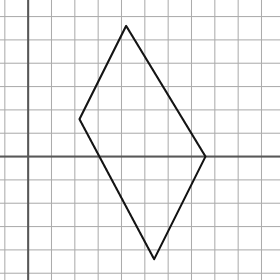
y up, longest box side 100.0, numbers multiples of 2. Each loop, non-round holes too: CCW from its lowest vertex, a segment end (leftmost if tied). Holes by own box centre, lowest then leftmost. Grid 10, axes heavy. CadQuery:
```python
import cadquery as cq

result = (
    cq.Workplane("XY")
    .moveTo(54.0, -44.0)
    .lineTo(76.0, 0.0)
    .lineTo(42.0, 56.0)
    .lineTo(22.0, 16.0)
    .close()
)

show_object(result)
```